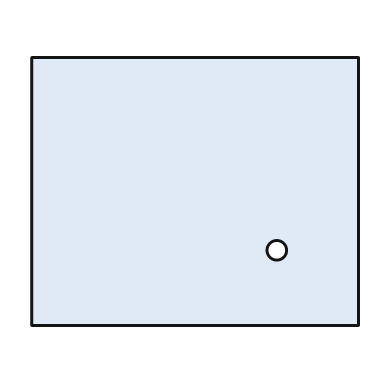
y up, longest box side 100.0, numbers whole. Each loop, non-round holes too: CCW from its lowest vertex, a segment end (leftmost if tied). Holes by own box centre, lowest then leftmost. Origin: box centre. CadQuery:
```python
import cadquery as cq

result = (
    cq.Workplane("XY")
    .moveTo(-50.0, -41.0)
    .lineTo(50.0, -41.0)
    .lineTo(50.0, 41.0)
    .lineTo(-50.0, 41.0)
    .close()
    .moveTo(25.0, -18.0)
    .circle(3.0)
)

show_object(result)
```